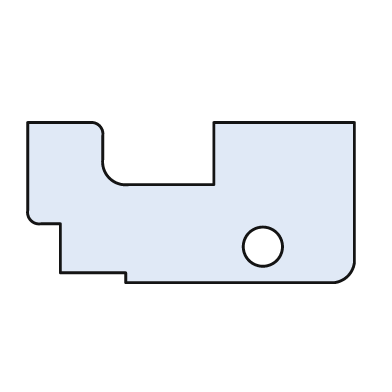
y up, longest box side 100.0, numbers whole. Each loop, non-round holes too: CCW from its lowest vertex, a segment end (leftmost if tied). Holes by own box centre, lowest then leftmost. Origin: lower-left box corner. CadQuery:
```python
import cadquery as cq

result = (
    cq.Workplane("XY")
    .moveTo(30.0, 0.0)
    .lineTo(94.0, 0.0)
    .threePointArc((98.0, 2.0), (100.0, 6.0))
    .lineTo(100.0, 49.0)
    .lineTo(57.0, 49.0)
    .lineTo(57.0, 30.0)
    .lineTo(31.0, 30.0)
    .threePointArc((25.0, 32.0), (23.0, 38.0))
    .lineTo(23.0, 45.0)
    .threePointArc((22.0, 48.0), (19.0, 49.0))
    .lineTo(0.0, 49.0)
    .lineTo(0.0, 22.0)
    .threePointArc((1.0, 19.0), (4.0, 18.0))
    .lineTo(10.0, 18.0)
    .lineTo(10.0, 3.0)
    .lineTo(30.0, 3.0)
    .close()
    .moveTo(72.0, 11.0)
    .circle(6.0)
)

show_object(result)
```